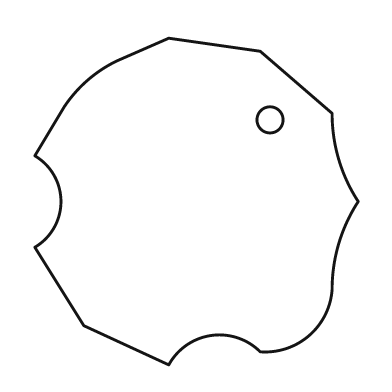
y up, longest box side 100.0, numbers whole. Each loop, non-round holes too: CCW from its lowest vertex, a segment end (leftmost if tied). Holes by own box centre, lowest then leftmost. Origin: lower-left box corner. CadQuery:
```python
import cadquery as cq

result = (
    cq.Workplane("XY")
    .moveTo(41.0, 0.0)
    .threePointArc((54.0, 9.0), (69.0, 4.0))
    .threePointArc((84.0, 9.0), (91.0, 23.0))
    .threePointArc((93.0, 37.0), (99.0, 50.0))
    .threePointArc((93.0, 63.0), (91.0, 77.0))
    .lineTo(69.0, 96.0)
    .lineTo(41.0, 100.0)
    .lineTo(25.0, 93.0)
    .threePointArc((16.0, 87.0), (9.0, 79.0))
    .lineTo(0.0, 64.0)
    .threePointArc((8.0, 50.0), (0.0, 36.0))
    .lineTo(15.0, 12.0)
    .close()
    .moveTo(72.0, 75.0)
    .circle(4.0)
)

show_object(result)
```